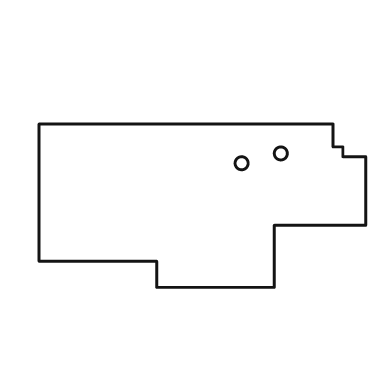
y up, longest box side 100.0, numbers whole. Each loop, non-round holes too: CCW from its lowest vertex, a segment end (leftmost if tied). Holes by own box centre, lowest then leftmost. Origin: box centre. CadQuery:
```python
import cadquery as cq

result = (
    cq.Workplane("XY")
    .moveTo(-14.0, -25.0)
    .lineTo(22.0, -25.0)
    .lineTo(22.0, -6.0)
    .lineTo(50.0, -6.0)
    .lineTo(50.0, 15.0)
    .lineTo(43.0, 15.0)
    .lineTo(43.0, 18.0)
    .lineTo(40.0, 18.0)
    .lineTo(40.0, 25.0)
    .lineTo(-50.0, 25.0)
    .lineTo(-50.0, -17.0)
    .lineTo(-14.0, -17.0)
    .close()
    .moveTo(12.0, 13.0)
    .circle(2.0)
    .moveTo(24.0, 16.0)
    .circle(2.0)
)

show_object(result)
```